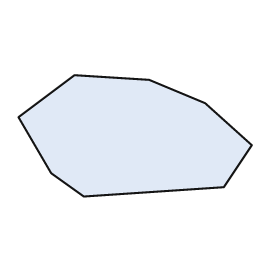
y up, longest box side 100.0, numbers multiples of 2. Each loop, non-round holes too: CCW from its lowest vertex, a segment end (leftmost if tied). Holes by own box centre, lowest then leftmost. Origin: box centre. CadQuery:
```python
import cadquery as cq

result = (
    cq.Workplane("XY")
    .moveTo(-22.0, -26.0)
    .lineTo(38.0, -22.0)
    .lineTo(50.0, -4.0)
    .lineTo(30.0, 14.0)
    .lineTo(6.0, 24.0)
    .lineTo(-26.0, 26.0)
    .lineTo(-50.0, 8.0)
    .lineTo(-36.0, -16.0)
    .close()
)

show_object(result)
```